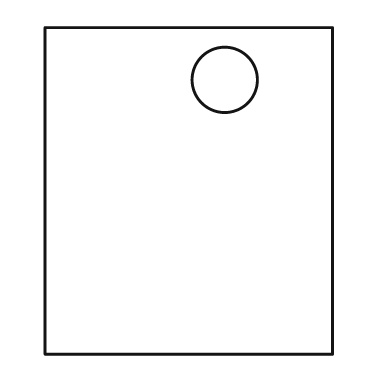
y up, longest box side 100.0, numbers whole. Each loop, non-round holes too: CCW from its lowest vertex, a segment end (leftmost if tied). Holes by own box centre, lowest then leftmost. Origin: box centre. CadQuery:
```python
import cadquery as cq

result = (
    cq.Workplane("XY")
    .moveTo(-44.0, -50.0)
    .lineTo(44.0, -50.0)
    .lineTo(44.0, 50.0)
    .lineTo(-44.0, 50.0)
    .close()
    .moveTo(11.0, 34.0)
    .circle(10.0)
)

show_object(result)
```